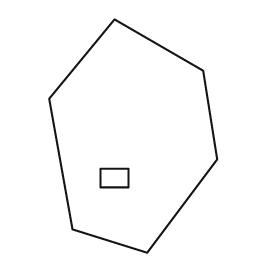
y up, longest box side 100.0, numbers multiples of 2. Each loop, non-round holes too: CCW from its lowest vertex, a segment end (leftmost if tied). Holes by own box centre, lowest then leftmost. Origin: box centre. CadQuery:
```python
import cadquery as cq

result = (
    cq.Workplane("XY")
    .moveTo(6.0, -50.0)
    .lineTo(36.0, -10.0)
    .lineTo(30.0, 28.0)
    .lineTo(-8.0, 50.0)
    .lineTo(-36.0, 16.0)
    .lineTo(-26.0, -40.0)
    .close()
    .moveTo(-14.0, -22.0)
    .lineTo(-2.0, -22.0)
    .lineTo(-2.0, -14.0)
    .lineTo(-14.0, -14.0)
    .close()
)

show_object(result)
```